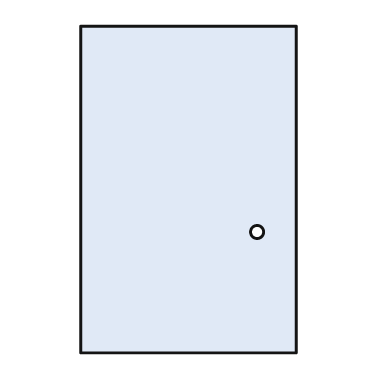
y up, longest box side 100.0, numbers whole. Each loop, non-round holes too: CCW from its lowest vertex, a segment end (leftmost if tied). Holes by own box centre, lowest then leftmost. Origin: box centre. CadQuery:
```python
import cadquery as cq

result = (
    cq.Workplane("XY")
    .moveTo(-33.0, -50.0)
    .lineTo(33.0, -50.0)
    .lineTo(33.0, 50.0)
    .lineTo(-33.0, 50.0)
    .close()
    .moveTo(21.0, -13.0)
    .circle(2.0)
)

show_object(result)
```